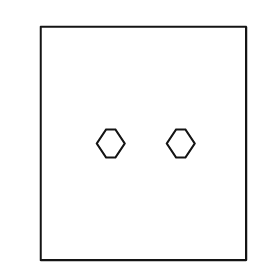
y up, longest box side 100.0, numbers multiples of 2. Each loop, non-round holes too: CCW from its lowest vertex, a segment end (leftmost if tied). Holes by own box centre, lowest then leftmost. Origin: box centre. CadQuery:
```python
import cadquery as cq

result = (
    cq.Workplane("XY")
    .moveTo(-44.0, -50.0)
    .lineTo(44.0, -50.0)
    .lineTo(44.0, 50.0)
    .lineTo(-44.0, 50.0)
    .close()
    .moveTo(-16.0, -6.0)
    .lineTo(-12.0, -6.0)
    .lineTo(-8.0, 0.0)
    .lineTo(-12.0, 6.0)
    .lineTo(-16.0, 6.0)
    .lineTo(-20.0, 0.0)
    .close()
    .moveTo(14.0, -6.0)
    .lineTo(18.0, -6.0)
    .lineTo(22.0, 0.0)
    .lineTo(18.0, 6.0)
    .lineTo(14.0, 6.0)
    .lineTo(10.0, 0.0)
    .close()
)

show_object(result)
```